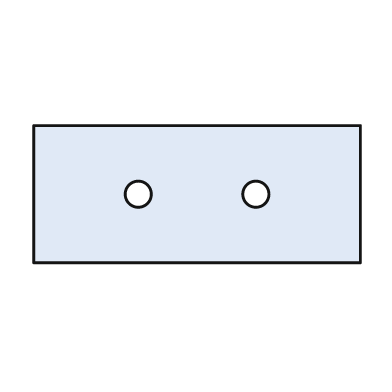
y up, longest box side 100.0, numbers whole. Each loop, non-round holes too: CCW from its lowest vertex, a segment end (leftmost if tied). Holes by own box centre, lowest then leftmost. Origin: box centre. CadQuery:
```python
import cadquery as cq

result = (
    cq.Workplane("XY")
    .moveTo(-50.0, -21.0)
    .lineTo(50.0, -21.0)
    .lineTo(50.0, 21.0)
    .lineTo(-50.0, 21.0)
    .close()
    .moveTo(-18.0, 0.0)
    .circle(4.0)
    .moveTo(18.0, 0.0)
    .circle(4.0)
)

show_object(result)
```